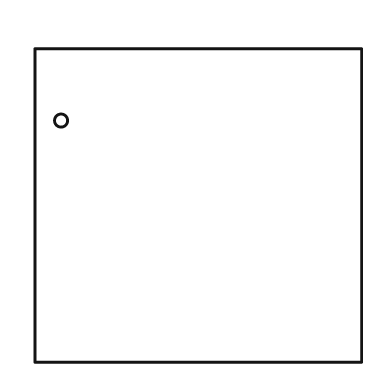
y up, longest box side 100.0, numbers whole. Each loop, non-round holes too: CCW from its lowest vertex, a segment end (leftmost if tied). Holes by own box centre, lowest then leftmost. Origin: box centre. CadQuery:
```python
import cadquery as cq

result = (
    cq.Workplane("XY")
    .moveTo(-50.0, -48.0)
    .lineTo(50.0, -48.0)
    .lineTo(50.0, 48.0)
    .lineTo(-50.0, 48.0)
    .close()
    .moveTo(-42.0, 26.0)
    .circle(2.0)
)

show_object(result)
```